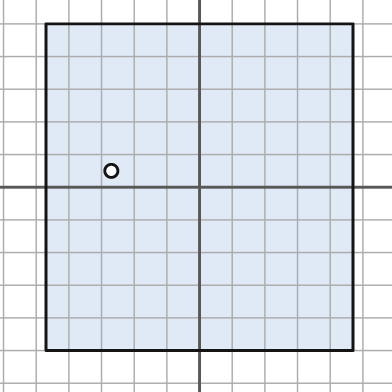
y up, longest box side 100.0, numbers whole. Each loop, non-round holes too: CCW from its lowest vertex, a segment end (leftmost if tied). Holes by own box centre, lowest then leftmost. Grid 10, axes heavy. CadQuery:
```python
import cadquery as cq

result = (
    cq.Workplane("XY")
    .moveTo(-47.0, -50.0)
    .lineTo(47.0, -50.0)
    .lineTo(47.0, 50.0)
    .lineTo(-47.0, 50.0)
    .close()
    .moveTo(-27.0, 5.0)
    .circle(2.0)
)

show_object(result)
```